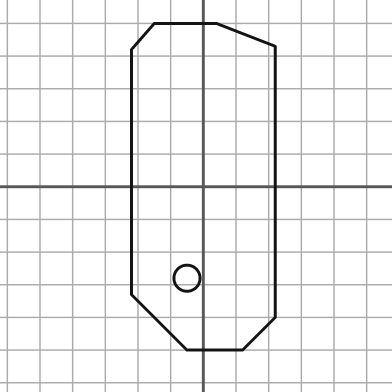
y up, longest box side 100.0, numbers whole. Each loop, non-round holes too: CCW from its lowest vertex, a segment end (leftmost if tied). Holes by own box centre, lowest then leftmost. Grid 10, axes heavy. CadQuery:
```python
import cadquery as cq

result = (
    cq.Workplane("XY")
    .moveTo(-5.0, -50.0)
    .lineTo(12.0, -50.0)
    .lineTo(22.0, -40.0)
    .lineTo(22.0, 43.0)
    .lineTo(4.0, 50.0)
    .lineTo(-15.0, 50.0)
    .lineTo(-22.0, 42.0)
    .lineTo(-22.0, -33.0)
    .close()
    .moveTo(-5.0, -28.0)
    .circle(4.0)
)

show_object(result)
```